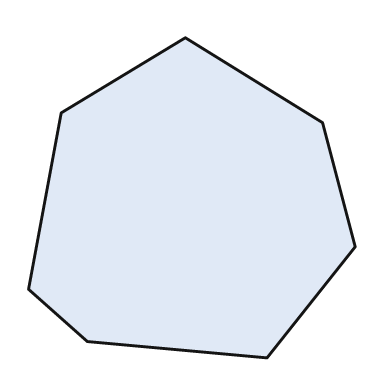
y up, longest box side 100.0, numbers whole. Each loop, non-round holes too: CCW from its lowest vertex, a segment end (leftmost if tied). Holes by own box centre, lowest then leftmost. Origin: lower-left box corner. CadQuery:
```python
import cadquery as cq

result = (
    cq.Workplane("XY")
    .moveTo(73.0, 0.0)
    .lineTo(100.0, 34.0)
    .lineTo(90.0, 72.0)
    .lineTo(48.0, 98.0)
    .lineTo(10.0, 75.0)
    .lineTo(0.0, 21.0)
    .lineTo(18.0, 5.0)
    .close()
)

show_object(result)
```